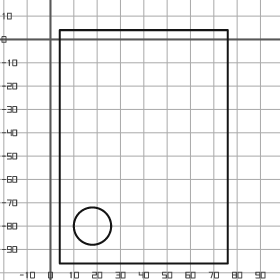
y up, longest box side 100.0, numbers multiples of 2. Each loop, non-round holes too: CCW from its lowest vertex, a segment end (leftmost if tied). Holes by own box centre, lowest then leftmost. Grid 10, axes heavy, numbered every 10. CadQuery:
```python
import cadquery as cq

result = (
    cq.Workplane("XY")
    .moveTo(4.0, -96.0)
    .lineTo(76.0, -96.0)
    .lineTo(76.0, 4.0)
    .lineTo(4.0, 4.0)
    .close()
    .moveTo(18.0, -80.0)
    .circle(8.0)
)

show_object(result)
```